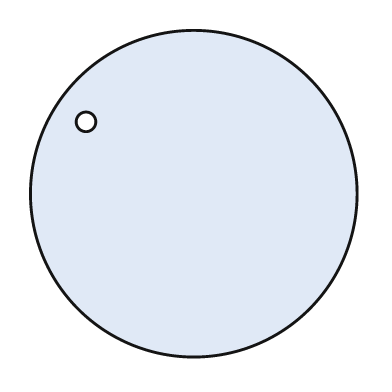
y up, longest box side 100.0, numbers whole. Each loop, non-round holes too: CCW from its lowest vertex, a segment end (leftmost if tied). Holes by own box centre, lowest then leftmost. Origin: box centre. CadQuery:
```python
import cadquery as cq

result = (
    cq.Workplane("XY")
    .moveTo(0.0, 0.0)
    .circle(50.0)
    .moveTo(-33.0, 22.0)
    .circle(3.0)
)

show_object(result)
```